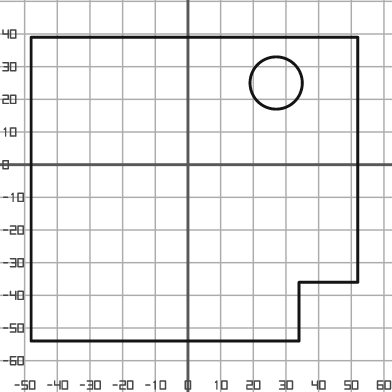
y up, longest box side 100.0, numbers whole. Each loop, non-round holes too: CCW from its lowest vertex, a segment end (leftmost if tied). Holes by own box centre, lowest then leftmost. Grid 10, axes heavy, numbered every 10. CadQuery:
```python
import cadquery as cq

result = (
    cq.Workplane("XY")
    .moveTo(-48.0, -54.0)
    .lineTo(34.0, -54.0)
    .lineTo(34.0, -36.0)
    .lineTo(52.0, -36.0)
    .lineTo(52.0, 39.0)
    .lineTo(-48.0, 39.0)
    .close()
    .moveTo(27.0, 25.0)
    .circle(8.0)
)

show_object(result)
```